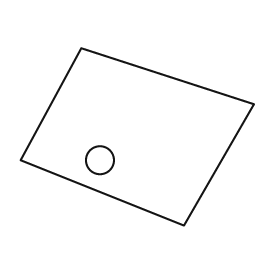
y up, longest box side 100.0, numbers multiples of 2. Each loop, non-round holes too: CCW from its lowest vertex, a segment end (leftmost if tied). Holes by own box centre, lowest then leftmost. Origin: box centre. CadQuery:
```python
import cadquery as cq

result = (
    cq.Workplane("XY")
    .moveTo(20.0, -38.0)
    .lineTo(50.0, 14.0)
    .lineTo(-24.0, 38.0)
    .lineTo(-50.0, -10.0)
    .close()
    .moveTo(-16.0, -10.0)
    .circle(6.0)
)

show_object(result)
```